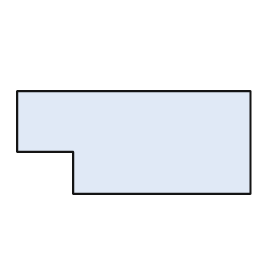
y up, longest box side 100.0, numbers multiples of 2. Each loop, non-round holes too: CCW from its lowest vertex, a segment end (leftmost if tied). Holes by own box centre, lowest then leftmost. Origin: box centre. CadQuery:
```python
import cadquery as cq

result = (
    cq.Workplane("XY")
    .moveTo(-26.0, -22.0)
    .lineTo(50.0, -22.0)
    .lineTo(50.0, 22.0)
    .lineTo(-50.0, 22.0)
    .lineTo(-50.0, -4.0)
    .lineTo(-26.0, -4.0)
    .close()
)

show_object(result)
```